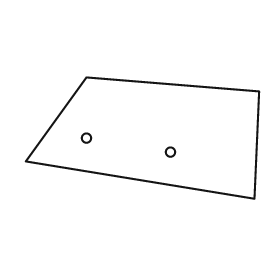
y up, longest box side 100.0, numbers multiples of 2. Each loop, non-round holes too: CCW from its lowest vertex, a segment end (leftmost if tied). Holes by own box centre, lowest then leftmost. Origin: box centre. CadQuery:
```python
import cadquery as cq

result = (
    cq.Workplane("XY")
    .moveTo(48.0, -26.0)
    .lineTo(50.0, 20.0)
    .lineTo(-24.0, 26.0)
    .lineTo(-50.0, -10.0)
    .close()
    .moveTo(12.0, -6.0)
    .circle(2.0)
    .moveTo(-24.0, 0.0)
    .circle(2.0)
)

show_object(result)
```